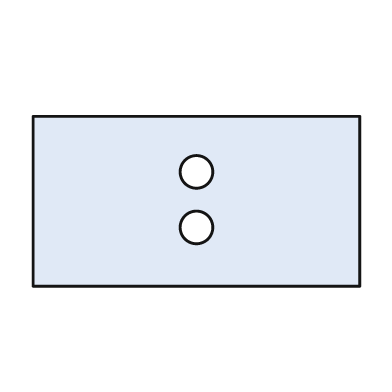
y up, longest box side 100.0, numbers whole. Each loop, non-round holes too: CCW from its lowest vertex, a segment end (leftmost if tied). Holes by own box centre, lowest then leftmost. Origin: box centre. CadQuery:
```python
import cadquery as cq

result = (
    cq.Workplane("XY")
    .moveTo(-50.0, -26.0)
    .lineTo(50.0, -26.0)
    .lineTo(50.0, 26.0)
    .lineTo(-50.0, 26.0)
    .close()
    .moveTo(0.0, -8.0)
    .circle(5.0)
    .moveTo(0.0, 9.0)
    .circle(5.0)
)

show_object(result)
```